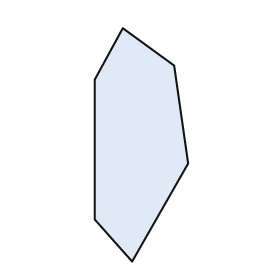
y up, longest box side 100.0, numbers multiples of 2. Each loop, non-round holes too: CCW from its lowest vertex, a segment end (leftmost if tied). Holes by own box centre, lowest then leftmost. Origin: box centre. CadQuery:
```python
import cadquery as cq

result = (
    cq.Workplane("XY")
    .moveTo(-4.0, -50.0)
    .lineTo(20.0, -8.0)
    .lineTo(14.0, 34.0)
    .lineTo(-8.0, 50.0)
    .lineTo(-20.0, 28.0)
    .lineTo(-20.0, -32.0)
    .close()
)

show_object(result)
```